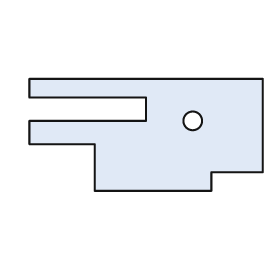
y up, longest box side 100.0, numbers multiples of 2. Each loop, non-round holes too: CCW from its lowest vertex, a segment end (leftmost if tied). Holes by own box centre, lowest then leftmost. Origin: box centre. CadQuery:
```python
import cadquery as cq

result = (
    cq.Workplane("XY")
    .moveTo(-22.0, -24.0)
    .lineTo(28.0, -24.0)
    .lineTo(28.0, -16.0)
    .lineTo(50.0, -16.0)
    .lineTo(50.0, 24.0)
    .lineTo(-50.0, 24.0)
    .lineTo(-50.0, 16.0)
    .lineTo(0.0, 16.0)
    .lineTo(0.0, 6.0)
    .lineTo(-50.0, 6.0)
    .lineTo(-50.0, -4.0)
    .lineTo(-22.0, -4.0)
    .close()
    .moveTo(20.0, 6.0)
    .circle(4.0)
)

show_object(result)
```